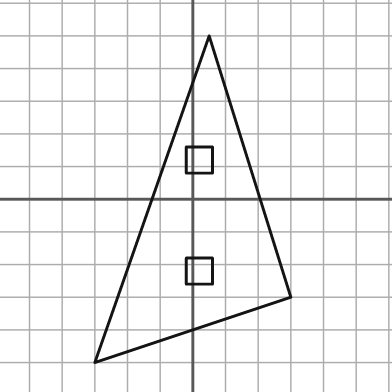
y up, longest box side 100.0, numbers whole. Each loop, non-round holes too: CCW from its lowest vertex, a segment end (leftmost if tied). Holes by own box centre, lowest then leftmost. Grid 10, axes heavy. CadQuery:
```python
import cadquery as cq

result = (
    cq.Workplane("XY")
    .moveTo(-30.0, -50.0)
    .lineTo(30.0, -30.0)
    .lineTo(5.0, 50.0)
    .close()
    .moveTo(-2.0, -26.0)
    .lineTo(6.0, -26.0)
    .lineTo(6.0, -18.0)
    .lineTo(-2.0, -18.0)
    .close()
    .moveTo(-2.0, 8.0)
    .lineTo(6.0, 8.0)
    .lineTo(6.0, 16.0)
    .lineTo(-2.0, 16.0)
    .close()
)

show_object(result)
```